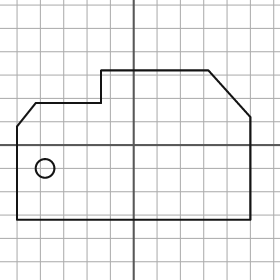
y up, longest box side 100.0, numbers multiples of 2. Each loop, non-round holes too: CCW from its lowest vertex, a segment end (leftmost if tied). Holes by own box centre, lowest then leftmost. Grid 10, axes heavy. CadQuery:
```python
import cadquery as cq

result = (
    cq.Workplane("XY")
    .moveTo(-50.0, -32.0)
    .lineTo(50.0, -32.0)
    .lineTo(50.0, 12.0)
    .lineTo(32.0, 32.0)
    .lineTo(-14.0, 32.0)
    .lineTo(-14.0, 18.0)
    .lineTo(-42.0, 18.0)
    .lineTo(-50.0, 8.0)
    .close()
    .moveTo(-38.0, -10.0)
    .circle(4.0)
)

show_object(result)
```